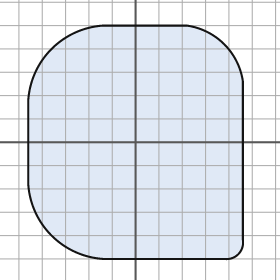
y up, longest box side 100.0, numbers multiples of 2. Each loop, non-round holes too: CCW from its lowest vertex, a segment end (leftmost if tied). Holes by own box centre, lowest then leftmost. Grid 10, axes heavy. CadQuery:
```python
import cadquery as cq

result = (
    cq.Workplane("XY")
    .moveTo(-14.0, -50.0)
    .lineTo(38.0, -50.0)
    .threePointArc((44.0, -48.0), (46.0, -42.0))
    .lineTo(46.0, 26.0)
    .threePointArc((38.0, 42.0), (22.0, 50.0))
    .lineTo(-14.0, 50.0)
    .threePointArc((-36.0, 40.0), (-46.0, 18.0))
    .lineTo(-46.0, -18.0)
    .threePointArc((-36.0, -40.0), (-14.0, -50.0))
    .close()
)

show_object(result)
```